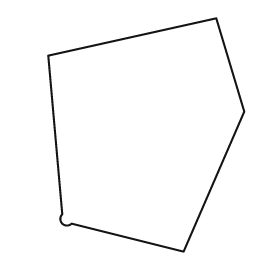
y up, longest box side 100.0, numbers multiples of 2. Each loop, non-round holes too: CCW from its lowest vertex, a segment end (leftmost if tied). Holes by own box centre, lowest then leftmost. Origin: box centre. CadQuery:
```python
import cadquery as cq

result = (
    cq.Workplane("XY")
    .moveTo(16.0, -50.0)
    .lineTo(42.0, 10.0)
    .lineTo(30.0, 50.0)
    .lineTo(-42.0, 34.0)
    .lineTo(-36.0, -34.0)
    .threePointArc((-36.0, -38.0), (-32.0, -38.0))
    .close()
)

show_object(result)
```